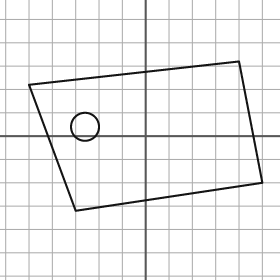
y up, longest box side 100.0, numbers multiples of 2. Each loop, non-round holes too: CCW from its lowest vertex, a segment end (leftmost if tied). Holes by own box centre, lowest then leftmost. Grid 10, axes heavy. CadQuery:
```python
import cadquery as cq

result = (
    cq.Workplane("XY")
    .moveTo(-30.0, -32.0)
    .lineTo(50.0, -20.0)
    .lineTo(40.0, 32.0)
    .lineTo(-50.0, 22.0)
    .close()
    .moveTo(-26.0, 4.0)
    .circle(6.0)
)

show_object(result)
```